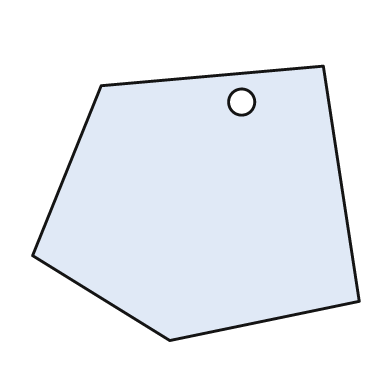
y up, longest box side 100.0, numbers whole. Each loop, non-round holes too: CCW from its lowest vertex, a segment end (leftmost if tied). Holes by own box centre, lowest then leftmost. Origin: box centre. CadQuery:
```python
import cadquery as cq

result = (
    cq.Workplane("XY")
    .moveTo(-8.0, -42.0)
    .lineTo(50.0, -30.0)
    .lineTo(39.0, 42.0)
    .lineTo(-29.0, 36.0)
    .lineTo(-50.0, -16.0)
    .close()
    .moveTo(14.0, 31.0)
    .circle(4.0)
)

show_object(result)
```